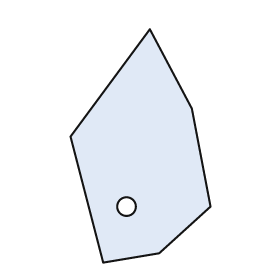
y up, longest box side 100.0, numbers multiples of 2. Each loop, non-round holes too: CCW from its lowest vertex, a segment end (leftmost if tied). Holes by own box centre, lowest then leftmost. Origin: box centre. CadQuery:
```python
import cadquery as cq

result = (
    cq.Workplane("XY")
    .moveTo(-16.0, -50.0)
    .lineTo(8.0, -46.0)
    .lineTo(30.0, -26.0)
    .lineTo(22.0, 16.0)
    .lineTo(4.0, 50.0)
    .lineTo(-30.0, 4.0)
    .close()
    .moveTo(-6.0, -26.0)
    .circle(4.0)
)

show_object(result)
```